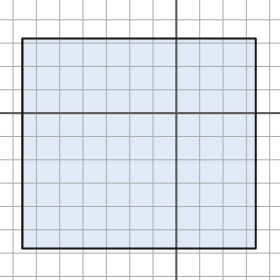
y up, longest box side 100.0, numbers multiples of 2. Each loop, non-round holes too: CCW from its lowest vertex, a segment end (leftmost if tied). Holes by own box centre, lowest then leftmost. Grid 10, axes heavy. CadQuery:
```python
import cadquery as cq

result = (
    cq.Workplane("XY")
    .moveTo(-66.0, -58.0)
    .lineTo(34.0, -58.0)
    .lineTo(34.0, 32.0)
    .lineTo(-66.0, 32.0)
    .close()
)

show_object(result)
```